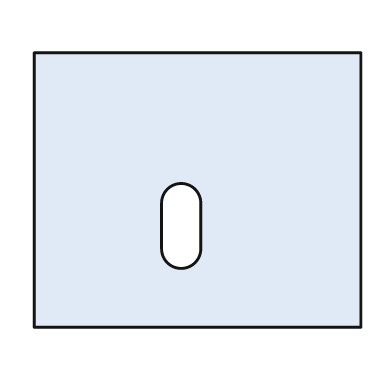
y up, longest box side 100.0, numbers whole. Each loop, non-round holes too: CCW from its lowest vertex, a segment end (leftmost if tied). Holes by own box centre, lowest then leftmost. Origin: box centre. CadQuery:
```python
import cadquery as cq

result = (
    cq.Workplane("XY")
    .moveTo(-50.0, -42.0)
    .lineTo(50.0, -42.0)
    .lineTo(50.0, 42.0)
    .lineTo(-50.0, 42.0)
    .close()
    .moveTo(-11.0, -18.0)
    .threePointArc((-5.0, -24.0), (1.0, -18.0))
    .lineTo(1.0, -4.0)
    .threePointArc((-5.0, 2.0), (-11.0, -4.0))
    .close()
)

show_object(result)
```